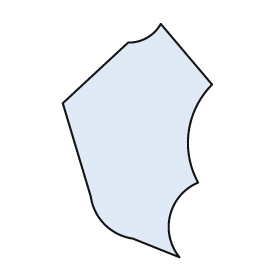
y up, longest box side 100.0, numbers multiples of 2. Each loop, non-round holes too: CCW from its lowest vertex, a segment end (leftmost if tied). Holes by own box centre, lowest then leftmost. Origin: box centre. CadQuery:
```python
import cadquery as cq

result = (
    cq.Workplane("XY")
    .moveTo(18.0, -50.0)
    .threePointArc((14.0, -32.0), (26.0, -18.0))
    .threePointArc((22.0, 4.0), (32.0, 24.0))
    .lineTo(10.0, 50.0)
    .threePointArc((4.0, 44.0), (-4.0, 42.0))
    .lineTo(-32.0, 16.0)
    .lineTo(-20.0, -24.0)
    .threePointArc((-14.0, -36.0), (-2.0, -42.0))
    .close()
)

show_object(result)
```